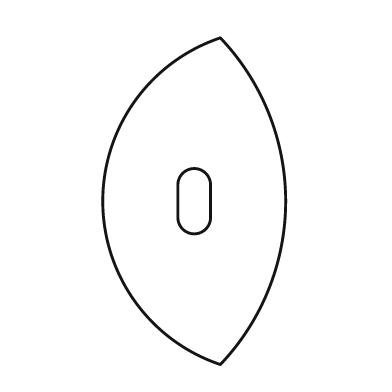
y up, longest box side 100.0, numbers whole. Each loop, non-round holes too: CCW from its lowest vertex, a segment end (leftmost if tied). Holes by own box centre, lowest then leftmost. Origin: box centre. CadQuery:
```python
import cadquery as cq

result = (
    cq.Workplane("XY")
    .moveTo(8.0, -50.0)
    .threePointArc((28.0, 0.0), (8.0, 50.0))
    .threePointArc((-28.0, 0.0), (8.0, -50.0))
    .close()
    .moveTo(-5.0, -5.0)
    .threePointArc((0.0, -10.0), (5.0, -5.0))
    .lineTo(5.0, 5.0)
    .threePointArc((0.0, 10.0), (-5.0, 5.0))
    .close()
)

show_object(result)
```